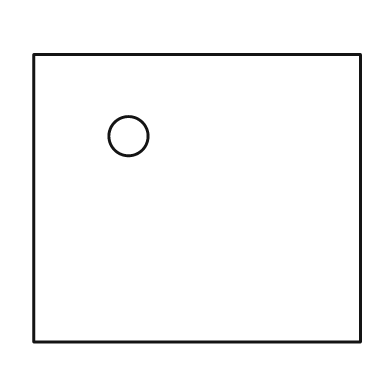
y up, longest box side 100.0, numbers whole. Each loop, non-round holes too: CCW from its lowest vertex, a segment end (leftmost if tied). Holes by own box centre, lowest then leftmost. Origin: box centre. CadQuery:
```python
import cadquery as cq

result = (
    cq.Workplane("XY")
    .moveTo(-50.0, -44.0)
    .lineTo(50.0, -44.0)
    .lineTo(50.0, 44.0)
    .lineTo(-50.0, 44.0)
    .close()
    .moveTo(-21.0, 19.0)
    .circle(6.0)
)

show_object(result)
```